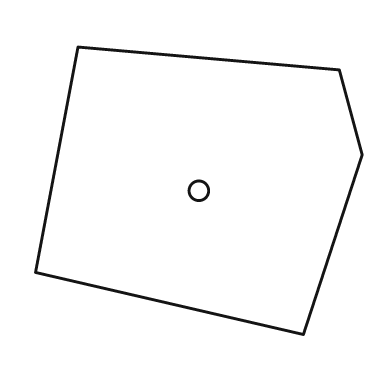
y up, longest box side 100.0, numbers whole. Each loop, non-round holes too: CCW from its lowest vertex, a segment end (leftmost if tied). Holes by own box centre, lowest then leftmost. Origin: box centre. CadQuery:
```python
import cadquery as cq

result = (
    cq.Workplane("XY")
    .moveTo(32.0, -44.0)
    .lineTo(50.0, 11.0)
    .lineTo(43.0, 37.0)
    .lineTo(-37.0, 44.0)
    .lineTo(-50.0, -25.0)
    .close()
    .moveTo(0.0, 0.0)
    .circle(3.0)
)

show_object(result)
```